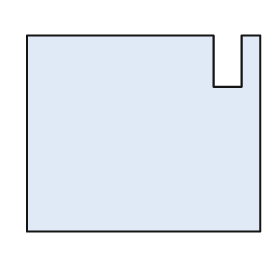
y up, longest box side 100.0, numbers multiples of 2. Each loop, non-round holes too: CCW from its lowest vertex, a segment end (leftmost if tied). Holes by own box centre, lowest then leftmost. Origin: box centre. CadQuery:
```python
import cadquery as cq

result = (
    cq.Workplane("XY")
    .moveTo(-50.0, -42.0)
    .lineTo(50.0, -42.0)
    .lineTo(50.0, 42.0)
    .lineTo(42.0, 42.0)
    .lineTo(42.0, 20.0)
    .lineTo(30.0, 20.0)
    .lineTo(30.0, 42.0)
    .lineTo(-50.0, 42.0)
    .close()
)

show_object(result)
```